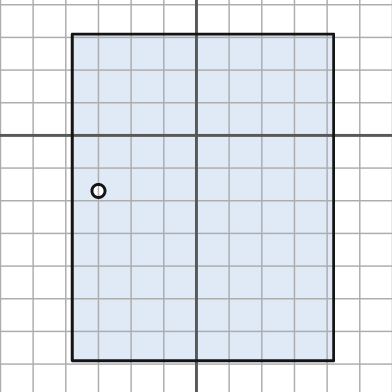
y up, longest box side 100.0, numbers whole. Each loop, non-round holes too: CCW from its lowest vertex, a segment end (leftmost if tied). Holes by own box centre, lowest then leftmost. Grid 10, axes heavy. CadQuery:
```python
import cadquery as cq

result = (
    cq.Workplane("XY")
    .moveTo(-38.0, -69.0)
    .lineTo(42.0, -69.0)
    .lineTo(42.0, 31.0)
    .lineTo(-38.0, 31.0)
    .close()
    .moveTo(-30.0, -17.0)
    .circle(2.0)
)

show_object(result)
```